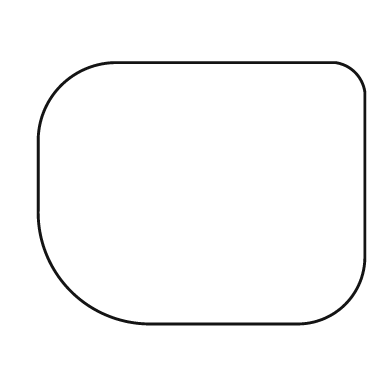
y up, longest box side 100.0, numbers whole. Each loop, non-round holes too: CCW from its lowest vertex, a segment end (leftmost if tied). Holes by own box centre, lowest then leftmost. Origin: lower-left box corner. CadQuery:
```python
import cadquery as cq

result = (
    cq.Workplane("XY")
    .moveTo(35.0, 0.0)
    .lineTo(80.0, 0.0)
    .threePointArc((94.0, 6.0), (100.0, 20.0))
    .lineTo(100.0, 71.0)
    .threePointArc((97.0, 77.0), (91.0, 80.0))
    .lineTo(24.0, 80.0)
    .threePointArc((7.0, 73.0), (0.0, 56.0))
    .lineTo(0.0, 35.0)
    .threePointArc((10.0, 10.0), (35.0, 0.0))
    .close()
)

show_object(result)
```